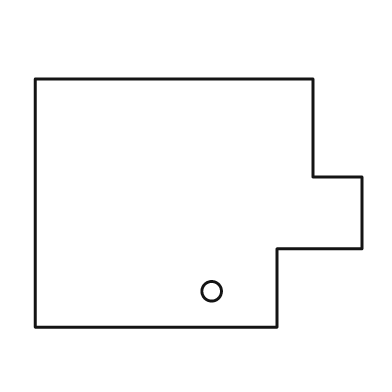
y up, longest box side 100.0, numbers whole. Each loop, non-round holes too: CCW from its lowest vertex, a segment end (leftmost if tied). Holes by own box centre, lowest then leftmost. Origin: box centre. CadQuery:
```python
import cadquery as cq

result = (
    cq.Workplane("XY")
    .moveTo(-50.0, -38.0)
    .lineTo(24.0, -38.0)
    .lineTo(24.0, -14.0)
    .lineTo(50.0, -14.0)
    .lineTo(50.0, 8.0)
    .lineTo(35.0, 8.0)
    .lineTo(35.0, 38.0)
    .lineTo(-50.0, 38.0)
    .close()
    .moveTo(4.0, -27.0)
    .circle(3.0)
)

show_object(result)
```